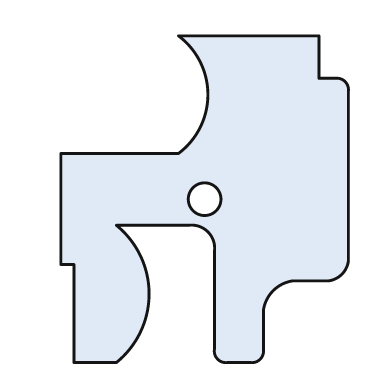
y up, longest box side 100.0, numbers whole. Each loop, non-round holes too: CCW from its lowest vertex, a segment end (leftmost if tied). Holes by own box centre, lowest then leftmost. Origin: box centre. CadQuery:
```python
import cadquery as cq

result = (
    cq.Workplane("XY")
    .moveTo(-40.0, -50.0)
    .lineTo(-27.0, -50.0)
    .threePointArc((-17.0, -29.0), (-27.0, -8.0))
    .lineTo(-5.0, -8.0)
    .threePointArc((1.0, -10.0), (3.0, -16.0))
    .lineTo(3.0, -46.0)
    .threePointArc((4.0, -49.0), (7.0, -50.0))
    .lineTo(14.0, -50.0)
    .threePointArc((17.0, -49.0), (18.0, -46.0))
    .lineTo(18.0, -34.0)
    .threePointArc((21.0, -28.0), (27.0, -25.0))
    .lineTo(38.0, -25.0)
    .threePointArc((42.0, -23.0), (44.0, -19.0))
    .lineTo(44.0, 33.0)
    .threePointArc((43.0, 36.0), (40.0, 37.0))
    .lineTo(35.0, 37.0)
    .lineTo(35.0, 50.0)
    .lineTo(-8.0, 50.0)
    .threePointArc((1.0, 32.0), (-8.0, 14.0))
    .lineTo(-44.0, 14.0)
    .lineTo(-44.0, -20.0)
    .lineTo(-40.0, -20.0)
    .close()
    .moveTo(0.0, 0.0)
    .circle(5.0)
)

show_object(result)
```